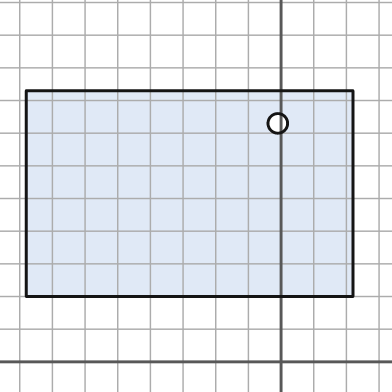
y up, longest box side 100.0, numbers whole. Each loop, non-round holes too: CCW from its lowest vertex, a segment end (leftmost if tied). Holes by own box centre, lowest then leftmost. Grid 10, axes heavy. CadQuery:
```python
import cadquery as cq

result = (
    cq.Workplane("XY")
    .moveTo(-78.0, 20.0)
    .lineTo(22.0, 20.0)
    .lineTo(22.0, 83.0)
    .lineTo(-78.0, 83.0)
    .close()
    .moveTo(-1.0, 73.0)
    .circle(3.0)
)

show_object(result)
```